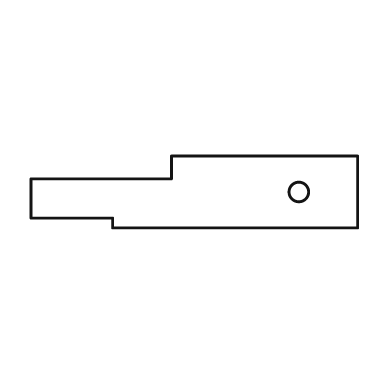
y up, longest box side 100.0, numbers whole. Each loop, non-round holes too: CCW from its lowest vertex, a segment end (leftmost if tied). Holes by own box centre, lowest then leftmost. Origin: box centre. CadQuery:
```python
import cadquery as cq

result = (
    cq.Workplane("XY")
    .moveTo(-25.0, -11.0)
    .lineTo(50.0, -11.0)
    .lineTo(50.0, 11.0)
    .lineTo(-7.0, 11.0)
    .lineTo(-7.0, 4.0)
    .lineTo(-50.0, 4.0)
    .lineTo(-50.0, -8.0)
    .lineTo(-25.0, -8.0)
    .close()
    .moveTo(32.0, 0.0)
    .circle(3.0)
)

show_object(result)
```